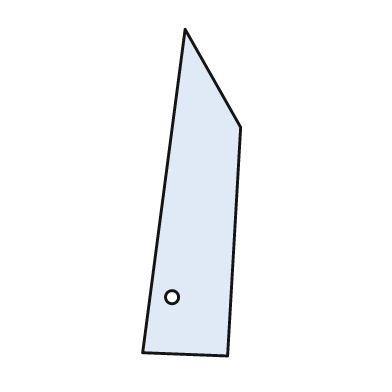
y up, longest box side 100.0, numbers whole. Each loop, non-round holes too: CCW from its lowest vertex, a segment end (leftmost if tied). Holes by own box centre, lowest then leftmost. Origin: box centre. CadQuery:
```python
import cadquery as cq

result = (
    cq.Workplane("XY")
    .moveTo(11.0, -50.0)
    .lineTo(15.0, 20.0)
    .lineTo(-2.0, 50.0)
    .lineTo(-15.0, -49.0)
    .close()
    .moveTo(-6.0, -32.0)
    .circle(2.0)
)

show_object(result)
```